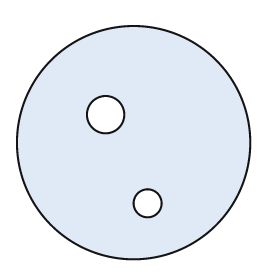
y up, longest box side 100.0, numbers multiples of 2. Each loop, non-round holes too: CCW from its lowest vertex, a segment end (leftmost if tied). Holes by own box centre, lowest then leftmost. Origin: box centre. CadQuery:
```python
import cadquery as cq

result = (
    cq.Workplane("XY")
    .moveTo(0.0, 0.0)
    .circle(50.0)
    .moveTo(6.0, -26.0)
    .circle(6.0)
    .moveTo(-12.0, 12.0)
    .circle(8.0)
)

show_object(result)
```